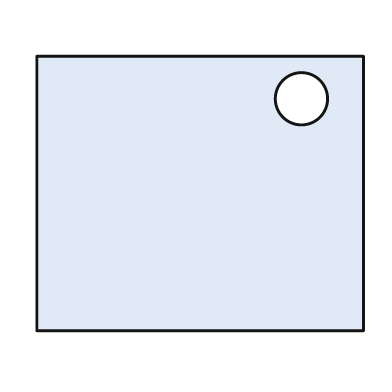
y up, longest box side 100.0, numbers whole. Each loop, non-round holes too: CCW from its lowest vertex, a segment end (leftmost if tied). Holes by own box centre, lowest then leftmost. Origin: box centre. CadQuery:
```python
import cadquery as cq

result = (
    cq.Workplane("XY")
    .moveTo(-50.0, -42.0)
    .lineTo(50.0, -42.0)
    .lineTo(50.0, 42.0)
    .lineTo(-50.0, 42.0)
    .close()
    .moveTo(31.0, 29.0)
    .circle(8.0)
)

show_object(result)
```